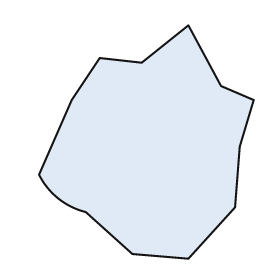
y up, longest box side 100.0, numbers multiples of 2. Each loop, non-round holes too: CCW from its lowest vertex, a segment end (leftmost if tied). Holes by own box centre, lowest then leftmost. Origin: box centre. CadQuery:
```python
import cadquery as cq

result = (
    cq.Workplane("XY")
    .moveTo(18.0, -50.0)
    .lineTo(38.0, -28.0)
    .lineTo(40.0, -2.0)
    .lineTo(46.0, 18.0)
    .lineTo(32.0, 24.0)
    .lineTo(18.0, 50.0)
    .lineTo(-2.0, 34.0)
    .lineTo(-20.0, 36.0)
    .lineTo(-32.0, 18.0)
    .lineTo(-46.0, -14.0)
    .threePointArc((-38.0, -24.0), (-26.0, -30.0))
    .lineTo(-6.0, -48.0)
    .close()
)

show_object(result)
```